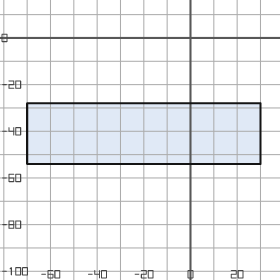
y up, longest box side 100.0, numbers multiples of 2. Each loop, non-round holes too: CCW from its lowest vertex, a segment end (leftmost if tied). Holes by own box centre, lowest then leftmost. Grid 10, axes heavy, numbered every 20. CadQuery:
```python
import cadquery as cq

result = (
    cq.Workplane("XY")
    .moveTo(-70.0, -54.0)
    .lineTo(30.0, -54.0)
    .lineTo(30.0, -28.0)
    .lineTo(-70.0, -28.0)
    .close()
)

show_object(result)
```